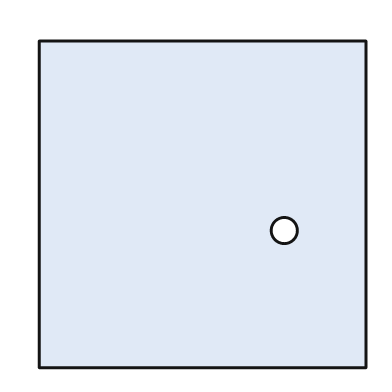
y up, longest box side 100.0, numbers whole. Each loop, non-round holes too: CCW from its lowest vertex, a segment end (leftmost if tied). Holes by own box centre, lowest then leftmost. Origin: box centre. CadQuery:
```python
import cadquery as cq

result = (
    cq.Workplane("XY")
    .moveTo(-50.0, -50.0)
    .lineTo(50.0, -50.0)
    .lineTo(50.0, 50.0)
    .lineTo(-50.0, 50.0)
    .close()
    .moveTo(25.0, -8.0)
    .circle(4.0)
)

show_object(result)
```